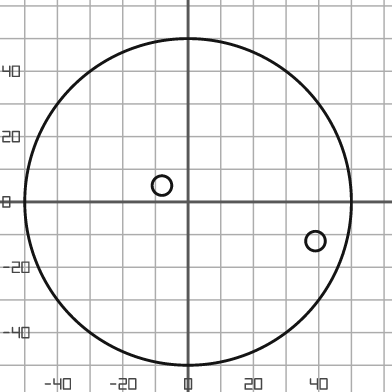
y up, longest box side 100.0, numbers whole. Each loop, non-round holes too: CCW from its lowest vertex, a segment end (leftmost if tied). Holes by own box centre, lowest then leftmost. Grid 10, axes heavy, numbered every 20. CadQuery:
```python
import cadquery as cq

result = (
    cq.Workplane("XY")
    .moveTo(0.0, 0.0)
    .circle(50.0)
    .moveTo(39.0, -12.0)
    .circle(3.0)
    .moveTo(-8.0, 5.0)
    .circle(3.0)
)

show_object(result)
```